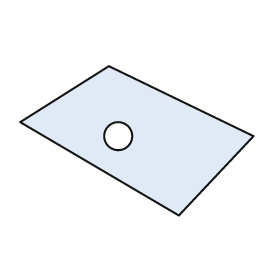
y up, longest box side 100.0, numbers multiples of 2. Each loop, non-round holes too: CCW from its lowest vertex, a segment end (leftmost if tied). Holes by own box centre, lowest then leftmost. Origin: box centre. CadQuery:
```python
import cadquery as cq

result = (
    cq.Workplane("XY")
    .moveTo(18.0, -32.0)
    .lineTo(50.0, 2.0)
    .lineTo(-12.0, 32.0)
    .lineTo(-50.0, 8.0)
    .close()
    .moveTo(-8.0, 2.0)
    .circle(6.0)
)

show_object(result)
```